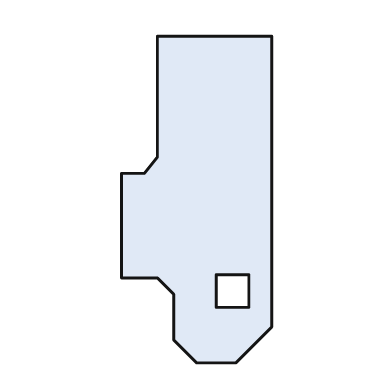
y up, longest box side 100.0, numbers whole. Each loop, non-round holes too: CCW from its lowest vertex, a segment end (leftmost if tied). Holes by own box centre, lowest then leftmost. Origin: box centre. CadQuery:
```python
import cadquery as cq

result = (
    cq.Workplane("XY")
    .moveTo(0.0, -50.0)
    .lineTo(12.0, -50.0)
    .lineTo(23.0, -39.0)
    .lineTo(23.0, 50.0)
    .lineTo(-12.0, 50.0)
    .lineTo(-12.0, 13.0)
    .lineTo(-16.0, 8.0)
    .lineTo(-23.0, 8.0)
    .lineTo(-23.0, -24.0)
    .lineTo(-12.0, -24.0)
    .lineTo(-7.0, -29.0)
    .lineTo(-7.0, -43.0)
    .close()
    .moveTo(6.0, -33.0)
    .lineTo(16.0, -33.0)
    .lineTo(16.0, -23.0)
    .lineTo(6.0, -23.0)
    .close()
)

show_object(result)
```